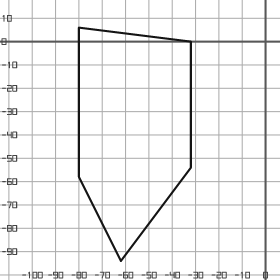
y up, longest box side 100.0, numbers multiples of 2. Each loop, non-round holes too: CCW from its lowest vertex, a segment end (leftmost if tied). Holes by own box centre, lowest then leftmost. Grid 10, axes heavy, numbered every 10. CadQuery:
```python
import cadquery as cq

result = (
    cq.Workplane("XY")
    .moveTo(-62.0, -94.0)
    .lineTo(-32.0, -54.0)
    .lineTo(-32.0, 0.0)
    .lineTo(-80.0, 6.0)
    .lineTo(-80.0, -58.0)
    .close()
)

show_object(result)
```